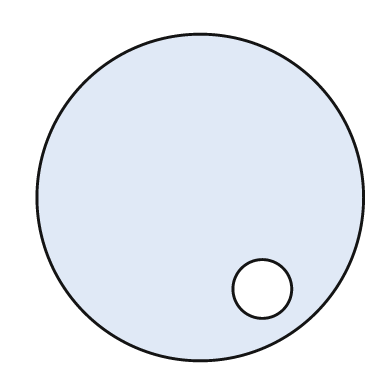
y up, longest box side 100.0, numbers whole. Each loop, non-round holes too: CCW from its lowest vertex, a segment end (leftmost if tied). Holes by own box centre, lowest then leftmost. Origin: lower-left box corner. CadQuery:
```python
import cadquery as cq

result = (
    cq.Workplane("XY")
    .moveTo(50.0, 50.0)
    .circle(50.0)
    .moveTo(69.0, 22.0)
    .circle(9.0)
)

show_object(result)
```